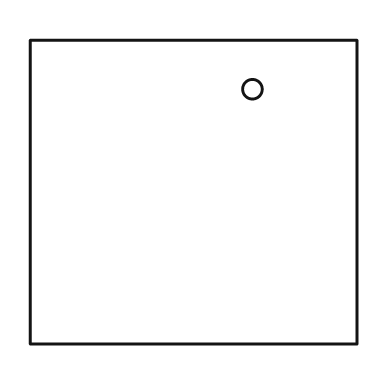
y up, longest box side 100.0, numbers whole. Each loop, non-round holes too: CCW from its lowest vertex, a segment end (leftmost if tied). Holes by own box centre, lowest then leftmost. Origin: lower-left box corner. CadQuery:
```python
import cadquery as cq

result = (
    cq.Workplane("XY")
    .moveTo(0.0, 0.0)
    .lineTo(100.0, 0.0)
    .lineTo(100.0, 93.0)
    .lineTo(0.0, 93.0)
    .close()
    .moveTo(68.0, 78.0)
    .circle(3.0)
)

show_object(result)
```